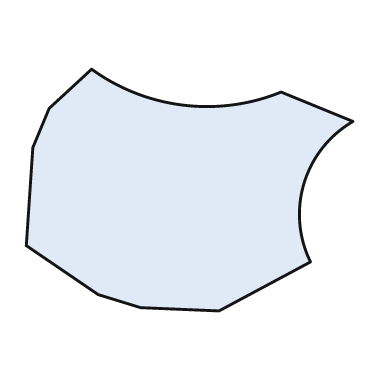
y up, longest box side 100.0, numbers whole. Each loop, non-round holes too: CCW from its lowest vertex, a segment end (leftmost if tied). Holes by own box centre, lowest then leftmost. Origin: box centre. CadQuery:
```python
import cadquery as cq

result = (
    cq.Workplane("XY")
    .moveTo(9.0, -37.0)
    .lineTo(37.0, -22.0)
    .threePointArc((35.0, 2.0), (50.0, 21.0))
    .lineTo(28.0, 30.0)
    .threePointArc((-2.0, 26.0), (-30.0, 37.0))
    .lineTo(-43.0, 25.0)
    .lineTo(-48.0, 13.0)
    .lineTo(-50.0, -17.0)
    .lineTo(-28.0, -32.0)
    .lineTo(-15.0, -36.0)
    .close()
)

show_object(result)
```